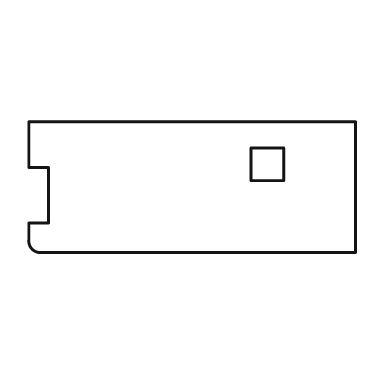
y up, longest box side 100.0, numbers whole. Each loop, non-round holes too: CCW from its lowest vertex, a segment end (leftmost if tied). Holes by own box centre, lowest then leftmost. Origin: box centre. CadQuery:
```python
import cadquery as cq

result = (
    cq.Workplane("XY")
    .moveTo(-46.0, -20.0)
    .lineTo(50.0, -20.0)
    .lineTo(50.0, 20.0)
    .lineTo(-50.0, 20.0)
    .lineTo(-50.0, 6.0)
    .lineTo(-44.0, 6.0)
    .lineTo(-44.0, -11.0)
    .lineTo(-50.0, -11.0)
    .lineTo(-50.0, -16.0)
    .threePointArc((-49.0, -19.0), (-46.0, -20.0))
    .close()
    .moveTo(18.0, 2.0)
    .lineTo(28.0, 2.0)
    .lineTo(28.0, 12.0)
    .lineTo(18.0, 12.0)
    .close()
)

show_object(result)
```